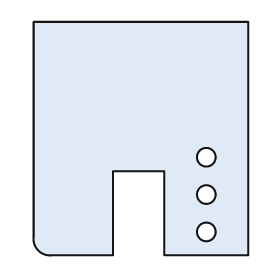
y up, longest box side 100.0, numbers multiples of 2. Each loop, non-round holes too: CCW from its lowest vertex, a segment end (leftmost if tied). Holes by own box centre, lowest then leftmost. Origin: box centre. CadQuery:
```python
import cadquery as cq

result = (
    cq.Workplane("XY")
    .moveTo(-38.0, -50.0)
    .lineTo(-12.0, -50.0)
    .lineTo(-12.0, -14.0)
    .lineTo(10.0, -14.0)
    .lineTo(10.0, -50.0)
    .lineTo(46.0, -50.0)
    .lineTo(46.0, 50.0)
    .lineTo(-46.0, 50.0)
    .lineTo(-46.0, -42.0)
    .threePointArc((-44.0, -48.0), (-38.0, -50.0))
    .close()
    .moveTo(28.0, -40.0)
    .circle(4.0)
    .moveTo(28.0, -24.0)
    .circle(4.0)
    .moveTo(28.0, -8.0)
    .circle(4.0)
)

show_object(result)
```